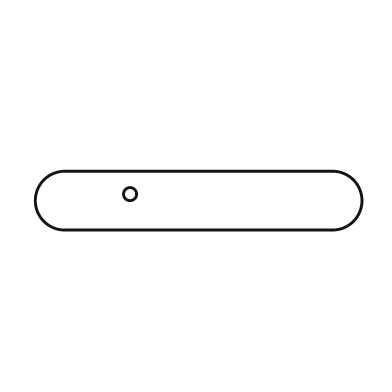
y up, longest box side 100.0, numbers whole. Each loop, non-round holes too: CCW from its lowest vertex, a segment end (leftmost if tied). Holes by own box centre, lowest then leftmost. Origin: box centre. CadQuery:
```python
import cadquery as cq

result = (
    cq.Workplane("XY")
    .moveTo(-41.0, -9.0)
    .lineTo(41.0, -9.0)
    .threePointArc((50.0, 0.0), (41.0, 9.0))
    .lineTo(-41.0, 9.0)
    .threePointArc((-50.0, 0.0), (-41.0, -9.0))
    .close()
    .moveTo(-21.0, 2.0)
    .circle(2.0)
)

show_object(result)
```